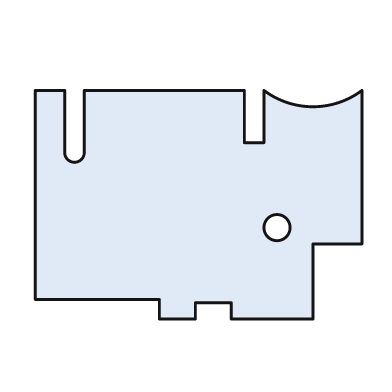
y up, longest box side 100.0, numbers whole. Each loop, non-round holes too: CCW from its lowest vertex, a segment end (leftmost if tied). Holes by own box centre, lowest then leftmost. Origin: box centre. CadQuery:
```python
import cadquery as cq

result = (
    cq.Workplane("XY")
    .moveTo(-12.0, -35.0)
    .lineTo(-1.0, -35.0)
    .lineTo(-1.0, -30.0)
    .lineTo(10.0, -30.0)
    .lineTo(10.0, -35.0)
    .lineTo(35.0, -35.0)
    .lineTo(35.0, -12.0)
    .lineTo(50.0, -12.0)
    .lineTo(50.0, 35.0)
    .threePointArc((35.0, 30.0), (20.0, 35.0))
    .lineTo(20.0, 19.0)
    .lineTo(14.0, 19.0)
    .lineTo(14.0, 35.0)
    .lineTo(-35.0, 35.0)
    .lineTo(-35.0, 16.0)
    .threePointArc((-38.0, 13.0), (-41.0, 16.0))
    .lineTo(-41.0, 35.0)
    .lineTo(-50.0, 35.0)
    .lineTo(-50.0, -29.0)
    .lineTo(-12.0, -29.0)
    .close()
    .moveTo(24.0, -7.0)
    .circle(4.0)
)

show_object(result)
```